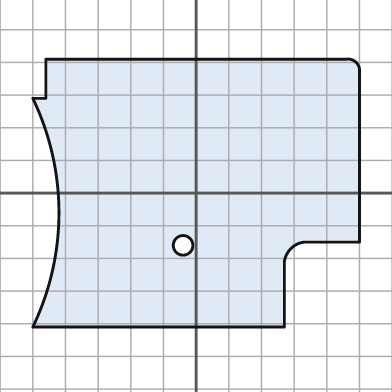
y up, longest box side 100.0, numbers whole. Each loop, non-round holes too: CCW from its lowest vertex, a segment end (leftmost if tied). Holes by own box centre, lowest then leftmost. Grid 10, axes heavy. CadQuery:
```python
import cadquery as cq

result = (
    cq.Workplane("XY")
    .moveTo(-50.0, -41.0)
    .lineTo(27.0, -41.0)
    .lineTo(27.0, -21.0)
    .threePointArc((29.0, -17.0), (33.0, -15.0))
    .lineTo(50.0, -15.0)
    .lineTo(50.0, 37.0)
    .threePointArc((49.0, 40.0), (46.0, 41.0))
    .lineTo(-46.0, 41.0)
    .lineTo(-46.0, 29.0)
    .lineTo(-50.0, 29.0)
    .threePointArc((-42.0, -6.0), (-50.0, -41.0))
    .close()
    .moveTo(-4.0, -16.0)
    .circle(3.0)
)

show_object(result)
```